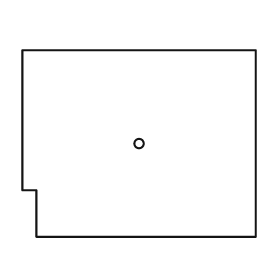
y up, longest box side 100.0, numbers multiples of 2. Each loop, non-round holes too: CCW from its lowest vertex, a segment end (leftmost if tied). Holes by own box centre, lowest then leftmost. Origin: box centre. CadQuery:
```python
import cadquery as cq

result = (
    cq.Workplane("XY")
    .moveTo(-44.0, -40.0)
    .lineTo(50.0, -40.0)
    .lineTo(50.0, 40.0)
    .lineTo(-50.0, 40.0)
    .lineTo(-50.0, -20.0)
    .lineTo(-44.0, -20.0)
    .close()
    .moveTo(0.0, 0.0)
    .circle(2.0)
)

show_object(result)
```